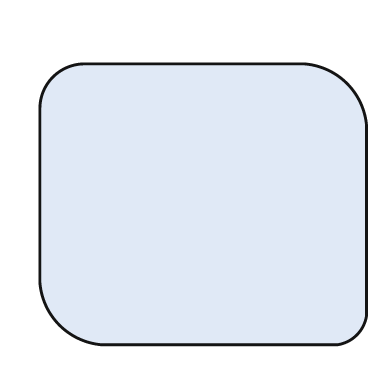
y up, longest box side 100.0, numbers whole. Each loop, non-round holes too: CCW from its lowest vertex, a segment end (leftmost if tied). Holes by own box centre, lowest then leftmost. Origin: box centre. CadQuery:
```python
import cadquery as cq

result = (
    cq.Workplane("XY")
    .moveTo(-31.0, -43.0)
    .lineTo(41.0, -43.0)
    .threePointArc((47.0, -40.0), (50.0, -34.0))
    .lineTo(50.0, 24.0)
    .threePointArc((44.0, 37.0), (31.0, 43.0))
    .lineTo(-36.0, 43.0)
    .threePointArc((-46.0, 39.0), (-50.0, 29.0))
    .lineTo(-50.0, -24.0)
    .threePointArc((-44.0, -37.0), (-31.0, -43.0))
    .close()
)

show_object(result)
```